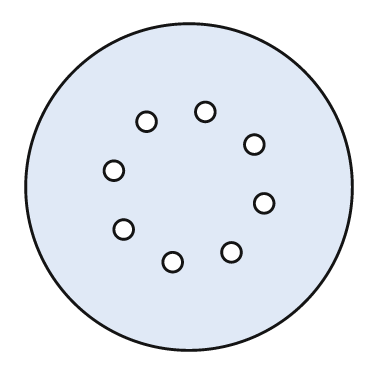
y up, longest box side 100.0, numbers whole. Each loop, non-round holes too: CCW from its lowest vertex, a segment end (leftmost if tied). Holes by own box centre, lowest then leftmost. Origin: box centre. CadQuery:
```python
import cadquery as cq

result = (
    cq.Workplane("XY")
    .moveTo(0.0, 0.0)
    .circle(50.0)
    .moveTo(-5.0, -23.0)
    .circle(3.0)
    .moveTo(13.0, -20.0)
    .circle(3.0)
    .moveTo(-20.0, -13.0)
    .circle(3.0)
    .moveTo(23.0, -5.0)
    .circle(3.0)
    .moveTo(-23.0, 5.0)
    .circle(3.0)
    .moveTo(20.0, 13.0)
    .circle(3.0)
    .moveTo(-13.0, 20.0)
    .circle(3.0)
    .moveTo(5.0, 23.0)
    .circle(3.0)
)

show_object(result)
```